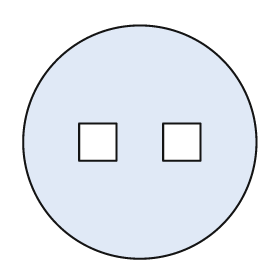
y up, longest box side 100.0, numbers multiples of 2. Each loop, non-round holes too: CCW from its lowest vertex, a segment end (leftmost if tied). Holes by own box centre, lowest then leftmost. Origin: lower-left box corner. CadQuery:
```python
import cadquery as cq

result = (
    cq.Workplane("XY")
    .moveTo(50.0, 50.0)
    .circle(50.0)
    .moveTo(24.0, 42.0)
    .lineTo(40.0, 42.0)
    .lineTo(40.0, 58.0)
    .lineTo(24.0, 58.0)
    .close()
    .moveTo(60.0, 42.0)
    .lineTo(76.0, 42.0)
    .lineTo(76.0, 58.0)
    .lineTo(60.0, 58.0)
    .close()
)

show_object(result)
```